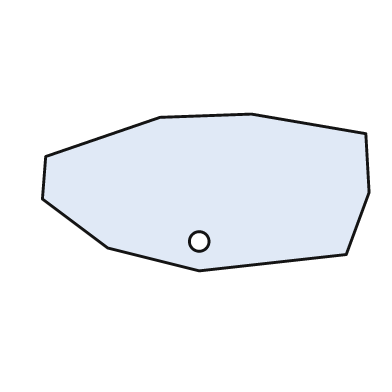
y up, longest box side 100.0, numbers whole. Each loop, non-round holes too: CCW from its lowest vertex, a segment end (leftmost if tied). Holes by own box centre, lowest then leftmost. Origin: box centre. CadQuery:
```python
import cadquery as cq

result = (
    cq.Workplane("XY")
    .moveTo(-2.0, -24.0)
    .lineTo(43.0, -19.0)
    .lineTo(50.0, 0.0)
    .lineTo(49.0, 18.0)
    .lineTo(14.0, 24.0)
    .lineTo(-14.0, 23.0)
    .lineTo(-49.0, 11.0)
    .lineTo(-50.0, -2.0)
    .lineTo(-30.0, -17.0)
    .close()
    .moveTo(-2.0, -15.0)
    .circle(3.0)
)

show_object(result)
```